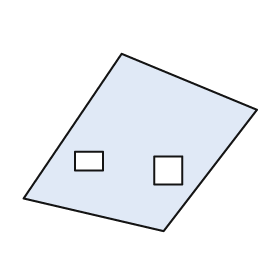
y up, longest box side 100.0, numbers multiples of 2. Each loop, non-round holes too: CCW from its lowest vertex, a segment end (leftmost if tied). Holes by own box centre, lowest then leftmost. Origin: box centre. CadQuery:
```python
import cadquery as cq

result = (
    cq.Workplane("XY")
    .moveTo(10.0, -38.0)
    .lineTo(50.0, 14.0)
    .lineTo(-8.0, 38.0)
    .lineTo(-50.0, -24.0)
    .close()
    .moveTo(6.0, -18.0)
    .lineTo(18.0, -18.0)
    .lineTo(18.0, -6.0)
    .lineTo(6.0, -6.0)
    .close()
    .moveTo(-28.0, -12.0)
    .lineTo(-16.0, -12.0)
    .lineTo(-16.0, -4.0)
    .lineTo(-28.0, -4.0)
    .close()
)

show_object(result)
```